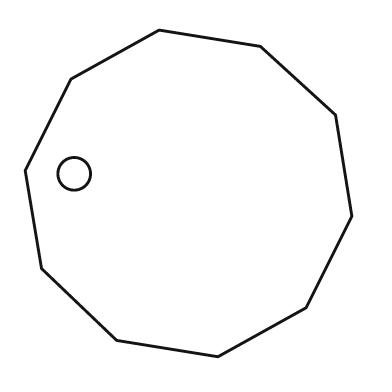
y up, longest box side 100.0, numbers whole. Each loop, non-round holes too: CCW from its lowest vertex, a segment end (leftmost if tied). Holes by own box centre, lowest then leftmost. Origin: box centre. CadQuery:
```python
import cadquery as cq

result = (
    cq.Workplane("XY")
    .moveTo(9.0, -50.0)
    .lineTo(36.0, -35.0)
    .lineTo(50.0, -7.0)
    .lineTo(45.0, 24.0)
    .lineTo(22.0, 45.0)
    .lineTo(-9.0, 50.0)
    .lineTo(-36.0, 35.0)
    .lineTo(-50.0, 7.0)
    .lineTo(-45.0, -23.0)
    .lineTo(-22.0, -45.0)
    .close()
    .moveTo(-35.0, 6.0)
    .circle(5.0)
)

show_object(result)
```